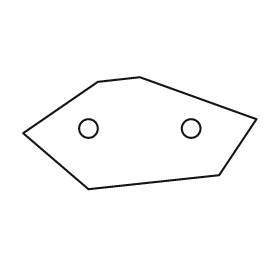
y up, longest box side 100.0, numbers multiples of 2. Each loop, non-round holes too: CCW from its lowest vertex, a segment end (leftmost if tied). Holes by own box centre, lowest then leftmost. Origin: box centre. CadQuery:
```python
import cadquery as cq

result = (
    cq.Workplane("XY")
    .moveTo(-22.0, -24.0)
    .lineTo(34.0, -18.0)
    .lineTo(50.0, 6.0)
    .lineTo(0.0, 24.0)
    .lineTo(-18.0, 22.0)
    .lineTo(-50.0, 0.0)
    .close()
    .moveTo(-22.0, 2.0)
    .circle(4.0)
    .moveTo(22.0, 2.0)
    .circle(4.0)
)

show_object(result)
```